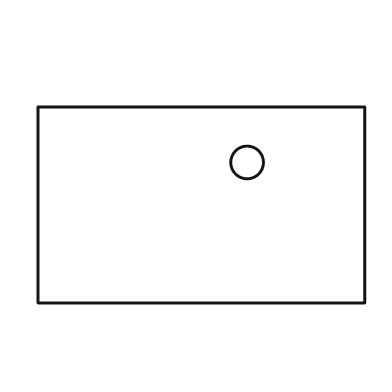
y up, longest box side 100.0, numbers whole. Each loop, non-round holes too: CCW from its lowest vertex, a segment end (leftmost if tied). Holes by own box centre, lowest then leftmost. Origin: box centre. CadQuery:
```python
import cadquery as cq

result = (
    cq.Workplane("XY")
    .moveTo(-50.0, -30.0)
    .lineTo(50.0, -30.0)
    .lineTo(50.0, 30.0)
    .lineTo(-50.0, 30.0)
    .close()
    .moveTo(14.0, 13.0)
    .circle(5.0)
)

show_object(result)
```